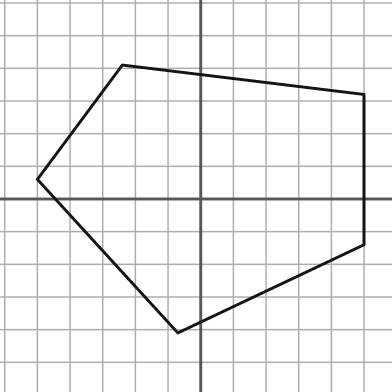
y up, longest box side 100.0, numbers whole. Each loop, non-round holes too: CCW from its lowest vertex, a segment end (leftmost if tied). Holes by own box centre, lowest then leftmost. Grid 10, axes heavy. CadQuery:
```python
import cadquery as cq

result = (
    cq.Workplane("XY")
    .moveTo(-7.0, -41.0)
    .lineTo(50.0, -14.0)
    .lineTo(50.0, 32.0)
    .lineTo(-24.0, 41.0)
    .lineTo(-50.0, 6.0)
    .close()
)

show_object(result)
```